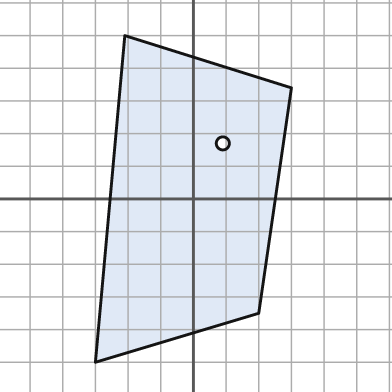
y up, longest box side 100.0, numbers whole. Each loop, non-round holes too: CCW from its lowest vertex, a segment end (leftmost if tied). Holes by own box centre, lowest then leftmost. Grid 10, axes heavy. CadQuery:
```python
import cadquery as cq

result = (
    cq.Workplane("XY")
    .moveTo(-30.0, -50.0)
    .lineTo(20.0, -35.0)
    .lineTo(30.0, 34.0)
    .lineTo(-21.0, 50.0)
    .close()
    .moveTo(9.0, 17.0)
    .circle(2.0)
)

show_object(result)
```